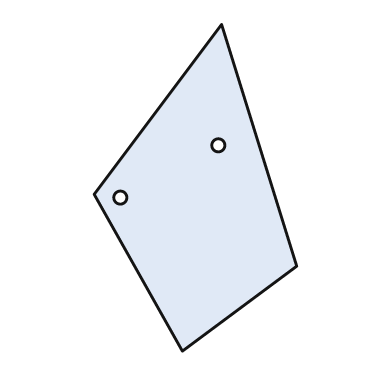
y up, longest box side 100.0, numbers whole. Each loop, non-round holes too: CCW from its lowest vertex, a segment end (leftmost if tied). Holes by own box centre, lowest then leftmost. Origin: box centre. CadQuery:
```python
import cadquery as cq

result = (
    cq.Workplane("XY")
    .moveTo(-4.0, -50.0)
    .lineTo(31.0, -24.0)
    .lineTo(8.0, 50.0)
    .lineTo(-31.0, -2.0)
    .close()
    .moveTo(-23.0, -3.0)
    .circle(2.0)
    .moveTo(7.0, 13.0)
    .circle(2.0)
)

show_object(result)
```